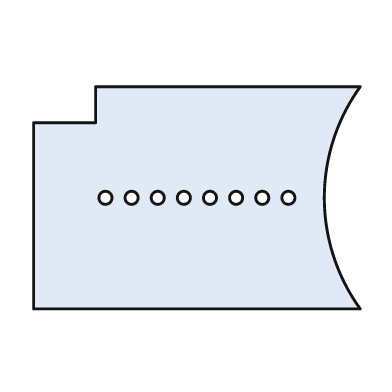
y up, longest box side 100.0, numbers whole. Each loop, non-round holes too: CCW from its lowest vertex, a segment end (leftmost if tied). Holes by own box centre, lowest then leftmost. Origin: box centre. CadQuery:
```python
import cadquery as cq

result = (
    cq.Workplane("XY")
    .moveTo(-50.0, -34.0)
    .lineTo(50.0, -34.0)
    .threePointArc((39.0, 0.0), (50.0, 34.0))
    .lineTo(-31.0, 34.0)
    .lineTo(-31.0, 23.0)
    .lineTo(-50.0, 23.0)
    .close()
    .moveTo(-28.0, 0.0)
    .circle(2.0)
    .moveTo(-20.0, 0.0)
    .circle(2.0)
    .moveTo(-12.0, 0.0)
    .circle(2.0)
    .moveTo(-4.0, 0.0)
    .circle(2.0)
    .moveTo(4.0, 0.0)
    .circle(2.0)
    .moveTo(12.0, 0.0)
    .circle(2.0)
    .moveTo(20.0, 0.0)
    .circle(2.0)
    .moveTo(28.0, 0.0)
    .circle(2.0)
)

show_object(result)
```